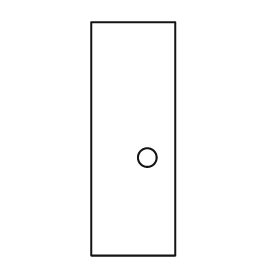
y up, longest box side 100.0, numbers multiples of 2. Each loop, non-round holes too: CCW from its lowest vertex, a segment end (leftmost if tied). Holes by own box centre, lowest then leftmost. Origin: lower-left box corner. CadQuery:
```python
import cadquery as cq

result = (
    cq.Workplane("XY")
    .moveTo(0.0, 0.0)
    .lineTo(36.0, 0.0)
    .lineTo(36.0, 100.0)
    .lineTo(0.0, 100.0)
    .close()
    .moveTo(24.0, 42.0)
    .circle(4.0)
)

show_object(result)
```